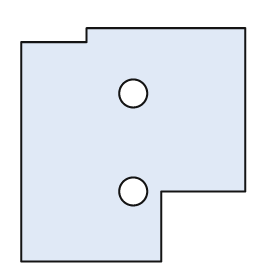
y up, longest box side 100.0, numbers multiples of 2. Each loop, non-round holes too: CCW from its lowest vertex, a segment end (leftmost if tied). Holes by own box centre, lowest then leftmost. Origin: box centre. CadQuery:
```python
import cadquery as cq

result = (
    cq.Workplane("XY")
    .moveTo(-48.0, -50.0)
    .lineTo(12.0, -50.0)
    .lineTo(12.0, -20.0)
    .lineTo(48.0, -20.0)
    .lineTo(48.0, 50.0)
    .lineTo(-20.0, 50.0)
    .lineTo(-20.0, 44.0)
    .lineTo(-48.0, 44.0)
    .close()
    .moveTo(0.0, -20.0)
    .circle(6.0)
    .moveTo(0.0, 22.0)
    .circle(6.0)
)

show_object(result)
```